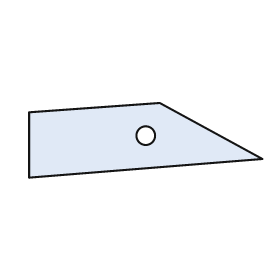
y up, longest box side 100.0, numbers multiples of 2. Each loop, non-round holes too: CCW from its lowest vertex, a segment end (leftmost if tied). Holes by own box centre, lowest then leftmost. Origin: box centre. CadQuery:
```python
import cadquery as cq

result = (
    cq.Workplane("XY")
    .moveTo(-50.0, -16.0)
    .lineTo(50.0, -8.0)
    .lineTo(6.0, 16.0)
    .lineTo(-50.0, 12.0)
    .close()
    .moveTo(0.0, 2.0)
    .circle(4.0)
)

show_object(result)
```